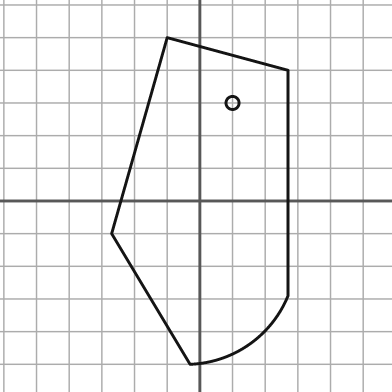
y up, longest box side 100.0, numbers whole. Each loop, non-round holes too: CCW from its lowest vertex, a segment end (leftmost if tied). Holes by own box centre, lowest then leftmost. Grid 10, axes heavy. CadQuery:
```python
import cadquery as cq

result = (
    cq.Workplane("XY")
    .moveTo(-3.0, -50.0)
    .threePointArc((15.0, -44.0), (27.0, -29.0))
    .lineTo(27.0, 40.0)
    .lineTo(-10.0, 50.0)
    .lineTo(-27.0, -10.0)
    .close()
    .moveTo(10.0, 30.0)
    .circle(2.0)
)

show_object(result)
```